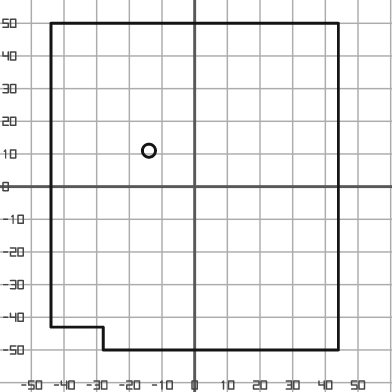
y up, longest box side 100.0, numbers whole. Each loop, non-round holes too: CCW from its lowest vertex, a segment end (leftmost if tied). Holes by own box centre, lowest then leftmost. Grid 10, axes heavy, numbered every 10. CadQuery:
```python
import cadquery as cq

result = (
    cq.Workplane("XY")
    .moveTo(-28.0, -50.0)
    .lineTo(44.0, -50.0)
    .lineTo(44.0, 50.0)
    .lineTo(-44.0, 50.0)
    .lineTo(-44.0, -43.0)
    .lineTo(-28.0, -43.0)
    .close()
    .moveTo(-14.0, 11.0)
    .circle(2.0)
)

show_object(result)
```